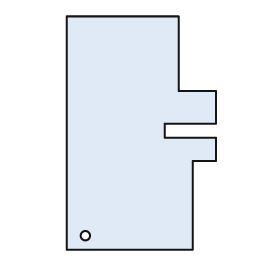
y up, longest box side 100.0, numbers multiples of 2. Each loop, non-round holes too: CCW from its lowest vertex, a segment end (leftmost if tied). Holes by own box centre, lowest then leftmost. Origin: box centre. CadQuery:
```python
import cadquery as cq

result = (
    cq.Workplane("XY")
    .moveTo(-32.0, -50.0)
    .lineTo(22.0, -50.0)
    .lineTo(22.0, -12.0)
    .lineTo(32.0, -12.0)
    .lineTo(32.0, -2.0)
    .lineTo(10.0, -2.0)
    .lineTo(10.0, 4.0)
    .lineTo(32.0, 4.0)
    .lineTo(32.0, 18.0)
    .lineTo(16.0, 18.0)
    .lineTo(16.0, 50.0)
    .lineTo(-32.0, 50.0)
    .close()
    .moveTo(-24.0, -44.0)
    .circle(2.0)
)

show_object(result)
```